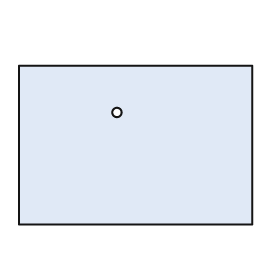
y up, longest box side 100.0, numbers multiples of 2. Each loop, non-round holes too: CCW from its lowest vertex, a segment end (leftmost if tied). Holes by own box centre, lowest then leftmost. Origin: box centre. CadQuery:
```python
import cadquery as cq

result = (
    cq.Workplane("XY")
    .moveTo(-50.0, -34.0)
    .lineTo(50.0, -34.0)
    .lineTo(50.0, 34.0)
    .lineTo(-50.0, 34.0)
    .close()
    .moveTo(-8.0, 14.0)
    .circle(2.0)
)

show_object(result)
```